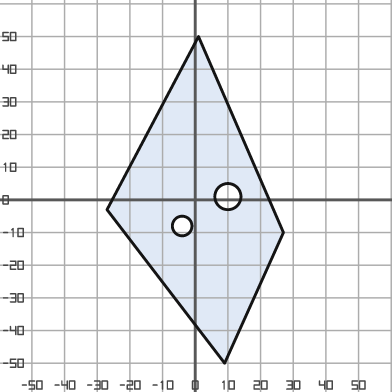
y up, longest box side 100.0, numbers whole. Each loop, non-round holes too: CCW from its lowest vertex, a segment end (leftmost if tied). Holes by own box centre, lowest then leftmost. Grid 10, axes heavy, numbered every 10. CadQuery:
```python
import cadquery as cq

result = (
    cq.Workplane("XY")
    .moveTo(9.0, -50.0)
    .lineTo(27.0, -10.0)
    .lineTo(1.0, 50.0)
    .lineTo(-27.0, -3.0)
    .close()
    .moveTo(-4.0, -8.0)
    .circle(3.0)
    .moveTo(10.0, 1.0)
    .circle(4.0)
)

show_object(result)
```